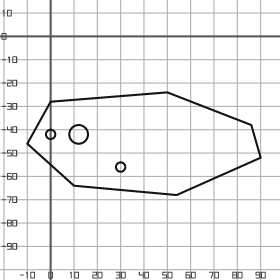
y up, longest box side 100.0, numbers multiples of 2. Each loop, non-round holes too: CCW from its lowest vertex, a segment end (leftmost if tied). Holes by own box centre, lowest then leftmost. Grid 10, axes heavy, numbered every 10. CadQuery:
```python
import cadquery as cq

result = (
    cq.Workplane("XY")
    .moveTo(54.0, -68.0)
    .lineTo(90.0, -52.0)
    .lineTo(86.0, -38.0)
    .lineTo(50.0, -24.0)
    .lineTo(0.0, -28.0)
    .lineTo(-10.0, -46.0)
    .lineTo(10.0, -64.0)
    .close()
    .moveTo(30.0, -56.0)
    .circle(2.0)
    .moveTo(0.0, -42.0)
    .circle(2.0)
    .moveTo(12.0, -42.0)
    .circle(4.0)
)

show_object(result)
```